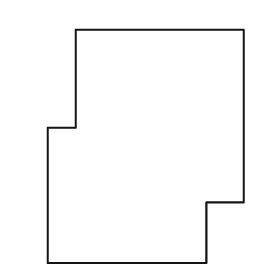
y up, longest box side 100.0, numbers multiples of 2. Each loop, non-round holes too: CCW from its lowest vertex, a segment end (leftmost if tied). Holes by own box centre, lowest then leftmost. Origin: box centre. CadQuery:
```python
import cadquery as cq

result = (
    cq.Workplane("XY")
    .moveTo(-42.0, -50.0)
    .lineTo(26.0, -50.0)
    .lineTo(26.0, -24.0)
    .lineTo(42.0, -24.0)
    .lineTo(42.0, 50.0)
    .lineTo(-30.0, 50.0)
    .lineTo(-30.0, 8.0)
    .lineTo(-42.0, 8.0)
    .close()
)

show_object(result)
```